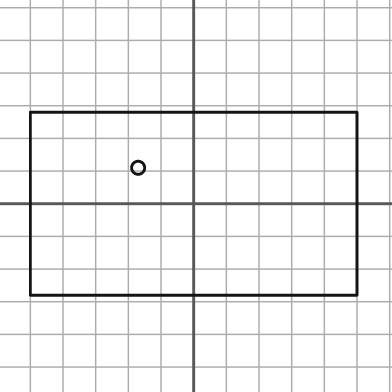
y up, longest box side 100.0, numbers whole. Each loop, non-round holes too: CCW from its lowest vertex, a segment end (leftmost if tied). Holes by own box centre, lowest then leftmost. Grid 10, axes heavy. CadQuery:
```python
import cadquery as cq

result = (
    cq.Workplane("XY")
    .moveTo(-50.0, -28.0)
    .lineTo(50.0, -28.0)
    .lineTo(50.0, 28.0)
    .lineTo(-50.0, 28.0)
    .close()
    .moveTo(-17.0, 11.0)
    .circle(2.0)
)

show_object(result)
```